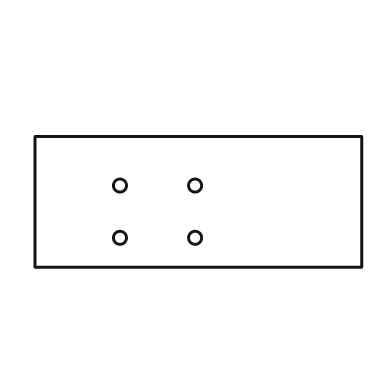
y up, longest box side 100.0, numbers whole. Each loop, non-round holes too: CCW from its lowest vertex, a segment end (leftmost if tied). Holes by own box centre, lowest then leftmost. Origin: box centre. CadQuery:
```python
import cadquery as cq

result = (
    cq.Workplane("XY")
    .moveTo(-50.0, -20.0)
    .lineTo(50.0, -20.0)
    .lineTo(50.0, 20.0)
    .lineTo(-50.0, 20.0)
    .close()
    .moveTo(-24.0, -11.0)
    .circle(2.0)
    .moveTo(-1.0, -11.0)
    .circle(2.0)
    .moveTo(-24.0, 5.0)
    .circle(2.0)
    .moveTo(-1.0, 5.0)
    .circle(2.0)
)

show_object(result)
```